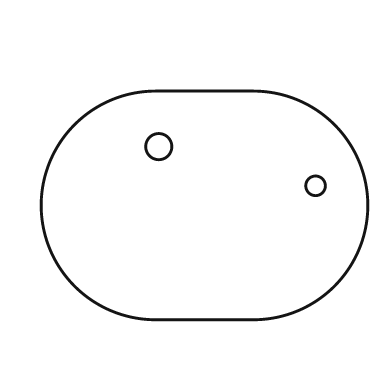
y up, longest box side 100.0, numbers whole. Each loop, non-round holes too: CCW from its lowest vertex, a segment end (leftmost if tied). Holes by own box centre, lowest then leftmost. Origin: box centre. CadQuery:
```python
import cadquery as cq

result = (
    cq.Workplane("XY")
    .moveTo(-15.0, -35.0)
    .lineTo(15.0, -35.0)
    .threePointArc((50.0, 0.0), (15.0, 35.0))
    .lineTo(-15.0, 35.0)
    .threePointArc((-50.0, 0.0), (-15.0, -35.0))
    .close()
    .moveTo(34.0, 6.0)
    .circle(3.0)
    .moveTo(-14.0, 18.0)
    .circle(4.0)
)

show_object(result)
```